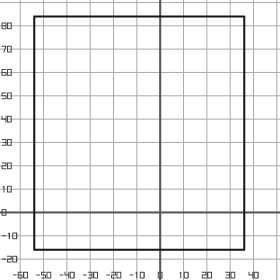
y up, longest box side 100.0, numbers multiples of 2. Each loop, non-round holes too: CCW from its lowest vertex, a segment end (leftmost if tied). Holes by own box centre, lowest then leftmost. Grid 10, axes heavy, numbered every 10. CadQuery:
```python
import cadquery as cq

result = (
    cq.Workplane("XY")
    .moveTo(-54.0, -16.0)
    .lineTo(36.0, -16.0)
    .lineTo(36.0, 84.0)
    .lineTo(-54.0, 84.0)
    .close()
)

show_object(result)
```